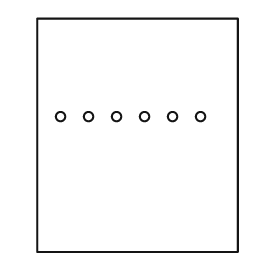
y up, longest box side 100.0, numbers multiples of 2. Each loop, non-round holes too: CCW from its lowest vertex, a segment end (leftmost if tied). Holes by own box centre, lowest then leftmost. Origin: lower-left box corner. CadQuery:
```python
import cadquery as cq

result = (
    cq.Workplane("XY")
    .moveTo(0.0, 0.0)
    .lineTo(86.0, 0.0)
    .lineTo(86.0, 100.0)
    .lineTo(0.0, 100.0)
    .close()
    .moveTo(10.0, 58.0)
    .circle(2.0)
    .moveTo(22.0, 58.0)
    .circle(2.0)
    .moveTo(34.0, 58.0)
    .circle(2.0)
    .moveTo(46.0, 58.0)
    .circle(2.0)
    .moveTo(58.0, 58.0)
    .circle(2.0)
    .moveTo(70.0, 58.0)
    .circle(2.0)
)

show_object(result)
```